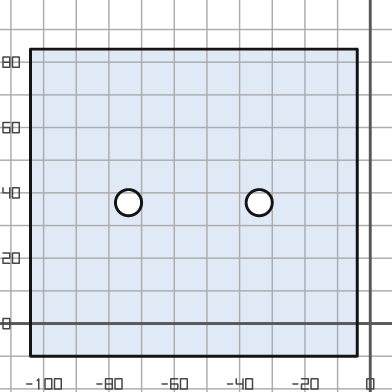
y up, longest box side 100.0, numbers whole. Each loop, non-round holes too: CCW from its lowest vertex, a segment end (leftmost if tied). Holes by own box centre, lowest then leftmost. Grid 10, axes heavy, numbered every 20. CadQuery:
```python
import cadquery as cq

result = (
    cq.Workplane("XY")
    .moveTo(-104.0, -10.0)
    .lineTo(-4.0, -10.0)
    .lineTo(-4.0, 84.0)
    .lineTo(-104.0, 84.0)
    .close()
    .moveTo(-74.0, 37.0)
    .circle(4.0)
    .moveTo(-34.0, 37.0)
    .circle(4.0)
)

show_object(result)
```